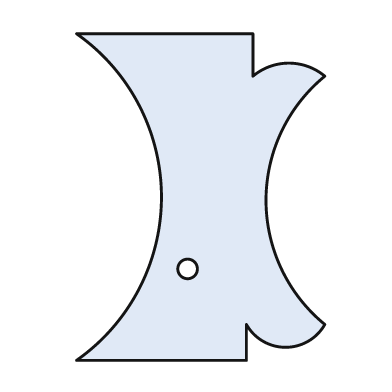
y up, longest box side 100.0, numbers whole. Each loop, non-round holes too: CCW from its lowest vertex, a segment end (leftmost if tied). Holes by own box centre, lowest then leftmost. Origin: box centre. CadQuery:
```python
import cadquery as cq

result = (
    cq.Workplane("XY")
    .moveTo(-38.0, -50.0)
    .lineTo(14.0, -50.0)
    .lineTo(14.0, -39.0)
    .threePointArc((26.0, -46.0), (38.0, -39.0))
    .threePointArc((20.0, -1.0), (38.0, 37.0))
    .threePointArc((27.0, 41.0), (16.0, 37.0))
    .lineTo(16.0, 50.0)
    .lineTo(-38.0, 50.0)
    .threePointArc((-12.0, 0.0), (-38.0, -50.0))
    .close()
    .moveTo(-4.0, -22.0)
    .circle(3.0)
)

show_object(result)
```